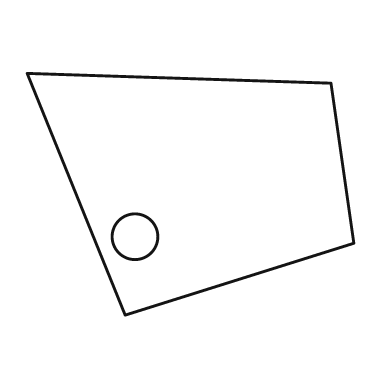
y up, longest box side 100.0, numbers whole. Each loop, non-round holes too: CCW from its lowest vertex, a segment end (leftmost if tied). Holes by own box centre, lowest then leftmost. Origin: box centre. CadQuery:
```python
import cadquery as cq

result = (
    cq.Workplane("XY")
    .moveTo(-20.0, -37.0)
    .lineTo(50.0, -15.0)
    .lineTo(43.0, 34.0)
    .lineTo(-50.0, 37.0)
    .close()
    .moveTo(-17.0, -13.0)
    .circle(7.0)
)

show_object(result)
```